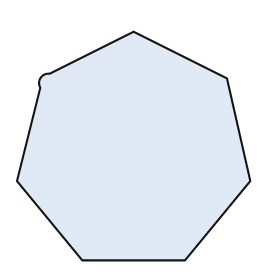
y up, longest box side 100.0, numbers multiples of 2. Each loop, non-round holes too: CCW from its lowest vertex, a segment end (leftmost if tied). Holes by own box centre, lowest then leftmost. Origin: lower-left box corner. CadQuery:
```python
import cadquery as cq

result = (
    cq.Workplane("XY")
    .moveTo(28.0, 0.0)
    .lineTo(72.0, 0.0)
    .lineTo(100.0, 34.0)
    .lineTo(90.0, 78.0)
    .lineTo(50.0, 98.0)
    .lineTo(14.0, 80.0)
    .threePointArc((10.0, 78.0), (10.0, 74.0))
    .lineTo(0.0, 34.0)
    .close()
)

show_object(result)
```